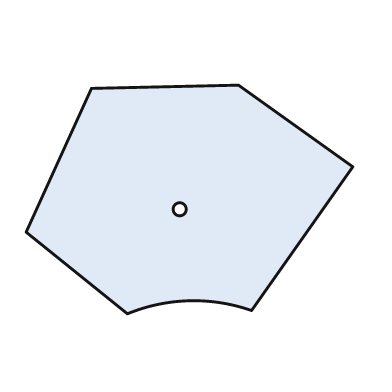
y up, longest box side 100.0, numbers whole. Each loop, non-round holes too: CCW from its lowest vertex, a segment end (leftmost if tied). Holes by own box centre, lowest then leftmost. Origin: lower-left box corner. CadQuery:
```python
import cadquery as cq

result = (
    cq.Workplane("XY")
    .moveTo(31.0, 0.0)
    .threePointArc((50.0, 4.0), (69.0, 1.0))
    .lineTo(100.0, 45.0)
    .lineTo(65.0, 70.0)
    .lineTo(20.0, 69.0)
    .lineTo(0.0, 25.0)
    .close()
    .moveTo(47.0, 32.0)
    .circle(2.0)
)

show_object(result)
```